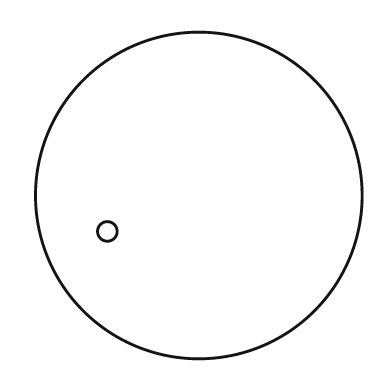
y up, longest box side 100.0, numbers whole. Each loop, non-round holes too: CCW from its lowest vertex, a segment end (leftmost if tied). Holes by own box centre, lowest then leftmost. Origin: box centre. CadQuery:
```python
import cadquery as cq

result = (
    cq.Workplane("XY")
    .moveTo(0.0, 0.0)
    .circle(50.0)
    .moveTo(-28.0, -11.0)
    .circle(3.0)
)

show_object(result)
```